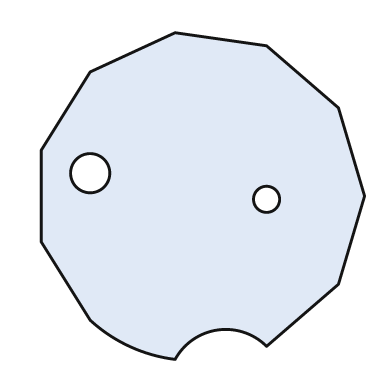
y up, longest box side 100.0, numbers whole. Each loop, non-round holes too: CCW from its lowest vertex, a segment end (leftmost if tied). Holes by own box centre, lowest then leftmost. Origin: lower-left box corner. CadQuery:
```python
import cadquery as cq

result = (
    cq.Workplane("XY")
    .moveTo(41.0, 0.0)
    .threePointArc((54.0, 9.0), (69.0, 4.0))
    .lineTo(91.0, 23.0)
    .lineTo(99.0, 50.0)
    .lineTo(91.0, 77.0)
    .lineTo(69.0, 96.0)
    .lineTo(41.0, 100.0)
    .lineTo(15.0, 88.0)
    .lineTo(0.0, 64.0)
    .lineTo(0.0, 36.0)
    .lineTo(15.0, 12.0)
    .threePointArc((27.0, 4.0), (41.0, 0.0))
    .close()
    .moveTo(69.0, 49.0)
    .circle(4.0)
    .moveTo(15.0, 57.0)
    .circle(6.0)
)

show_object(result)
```